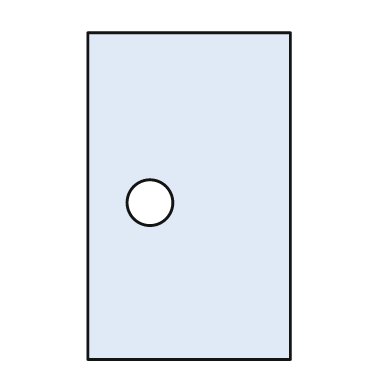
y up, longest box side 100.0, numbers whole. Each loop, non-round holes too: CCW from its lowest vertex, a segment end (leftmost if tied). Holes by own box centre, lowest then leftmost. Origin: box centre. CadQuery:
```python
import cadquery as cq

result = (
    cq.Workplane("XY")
    .moveTo(-31.0, -50.0)
    .lineTo(31.0, -50.0)
    .lineTo(31.0, 50.0)
    .lineTo(-31.0, 50.0)
    .close()
    .moveTo(-12.0, -2.0)
    .circle(7.0)
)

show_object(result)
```